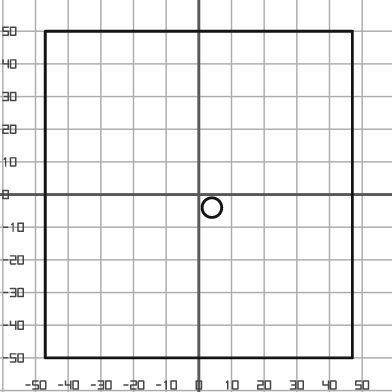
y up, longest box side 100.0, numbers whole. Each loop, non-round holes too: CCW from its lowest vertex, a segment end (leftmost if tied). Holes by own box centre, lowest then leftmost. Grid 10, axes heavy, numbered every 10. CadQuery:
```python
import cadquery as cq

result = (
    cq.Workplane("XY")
    .moveTo(-47.0, -50.0)
    .lineTo(47.0, -50.0)
    .lineTo(47.0, 50.0)
    .lineTo(-47.0, 50.0)
    .close()
    .moveTo(4.0, -4.0)
    .circle(3.0)
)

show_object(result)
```